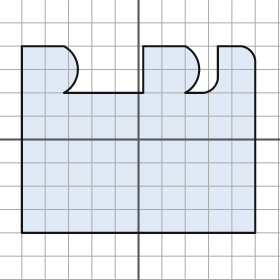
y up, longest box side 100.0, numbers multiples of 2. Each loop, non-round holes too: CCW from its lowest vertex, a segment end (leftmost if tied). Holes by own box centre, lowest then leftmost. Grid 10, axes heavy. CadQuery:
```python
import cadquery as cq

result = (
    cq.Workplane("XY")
    .moveTo(-50.0, -40.0)
    .lineTo(50.0, -40.0)
    .lineTo(50.0, 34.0)
    .threePointArc((48.0, 38.0), (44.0, 40.0))
    .lineTo(34.0, 40.0)
    .lineTo(34.0, 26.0)
    .threePointArc((32.0, 22.0), (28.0, 20.0))
    .lineTo(20.0, 20.0)
    .threePointArc((26.0, 30.0), (20.0, 40.0))
    .lineTo(2.0, 40.0)
    .lineTo(2.0, 20.0)
    .lineTo(-32.0, 20.0)
    .threePointArc((-26.0, 30.0), (-32.0, 40.0))
    .lineTo(-50.0, 40.0)
    .close()
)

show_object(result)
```